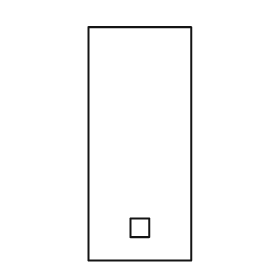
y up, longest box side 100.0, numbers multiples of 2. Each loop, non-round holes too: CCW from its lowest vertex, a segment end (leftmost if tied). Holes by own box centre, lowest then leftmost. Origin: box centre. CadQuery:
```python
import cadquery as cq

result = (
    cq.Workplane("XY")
    .moveTo(-22.0, -50.0)
    .lineTo(22.0, -50.0)
    .lineTo(22.0, 50.0)
    .lineTo(-22.0, 50.0)
    .close()
    .moveTo(-4.0, -40.0)
    .lineTo(4.0, -40.0)
    .lineTo(4.0, -32.0)
    .lineTo(-4.0, -32.0)
    .close()
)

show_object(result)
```